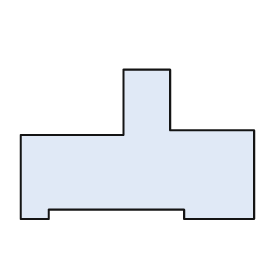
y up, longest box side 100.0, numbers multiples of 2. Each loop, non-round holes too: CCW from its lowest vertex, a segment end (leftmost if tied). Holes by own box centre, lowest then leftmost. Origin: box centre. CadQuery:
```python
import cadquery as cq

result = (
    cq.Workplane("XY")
    .moveTo(-50.0, -32.0)
    .lineTo(-38.0, -32.0)
    .lineTo(-38.0, -28.0)
    .lineTo(20.0, -28.0)
    .lineTo(20.0, -32.0)
    .lineTo(50.0, -32.0)
    .lineTo(50.0, 6.0)
    .lineTo(14.0, 6.0)
    .lineTo(14.0, 32.0)
    .lineTo(-6.0, 32.0)
    .lineTo(-6.0, 4.0)
    .lineTo(-50.0, 4.0)
    .close()
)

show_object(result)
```